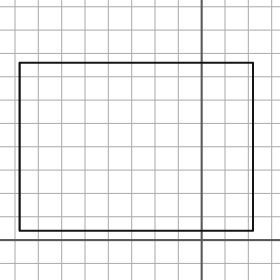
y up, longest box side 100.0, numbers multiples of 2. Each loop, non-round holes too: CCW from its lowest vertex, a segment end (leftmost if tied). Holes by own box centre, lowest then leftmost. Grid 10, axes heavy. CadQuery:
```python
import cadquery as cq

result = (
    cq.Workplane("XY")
    .moveTo(-78.0, 4.0)
    .lineTo(22.0, 4.0)
    .lineTo(22.0, 76.0)
    .lineTo(-78.0, 76.0)
    .close()
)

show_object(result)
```